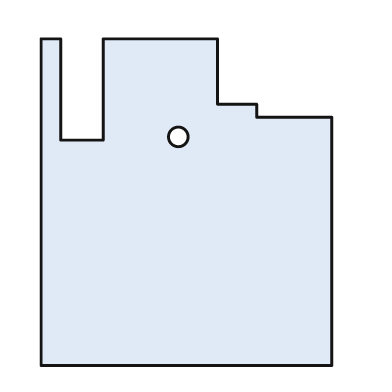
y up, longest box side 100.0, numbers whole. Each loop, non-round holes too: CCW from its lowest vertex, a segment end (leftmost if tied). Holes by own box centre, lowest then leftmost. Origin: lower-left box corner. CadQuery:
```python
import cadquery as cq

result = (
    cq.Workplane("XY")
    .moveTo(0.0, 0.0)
    .lineTo(89.0, 0.0)
    .lineTo(89.0, 76.0)
    .lineTo(66.0, 76.0)
    .lineTo(66.0, 80.0)
    .lineTo(54.0, 80.0)
    .lineTo(54.0, 100.0)
    .lineTo(19.0, 100.0)
    .lineTo(19.0, 69.0)
    .lineTo(6.0, 69.0)
    .lineTo(6.0, 100.0)
    .lineTo(0.0, 100.0)
    .close()
    .moveTo(42.0, 70.0)
    .circle(3.0)
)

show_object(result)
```